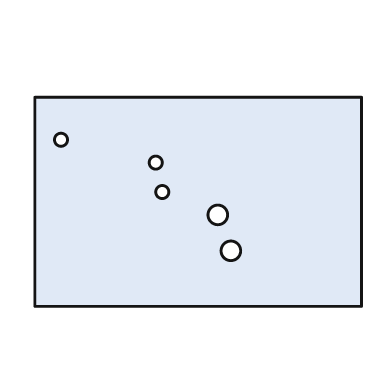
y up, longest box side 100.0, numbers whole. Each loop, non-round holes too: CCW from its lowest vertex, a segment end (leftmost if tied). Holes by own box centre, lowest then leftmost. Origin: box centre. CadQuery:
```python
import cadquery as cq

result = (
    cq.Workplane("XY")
    .moveTo(-50.0, -32.0)
    .lineTo(50.0, -32.0)
    .lineTo(50.0, 32.0)
    .lineTo(-50.0, 32.0)
    .close()
    .moveTo(10.0, -15.0)
    .circle(3.0)
    .moveTo(6.0, -4.0)
    .circle(3.0)
    .moveTo(-11.0, 3.0)
    .circle(2.0)
    .moveTo(-13.0, 12.0)
    .circle(2.0)
    .moveTo(-42.0, 19.0)
    .circle(2.0)
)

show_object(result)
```